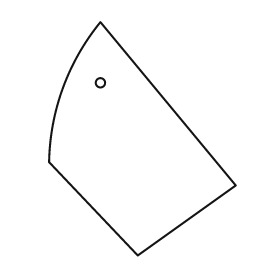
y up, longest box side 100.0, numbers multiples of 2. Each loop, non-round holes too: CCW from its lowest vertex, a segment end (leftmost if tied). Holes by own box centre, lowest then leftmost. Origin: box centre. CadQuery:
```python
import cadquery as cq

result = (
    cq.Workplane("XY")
    .moveTo(-2.0, -50.0)
    .lineTo(40.0, -20.0)
    .lineTo(-18.0, 50.0)
    .threePointArc((-34.0, 22.0), (-40.0, -10.0))
    .close()
    .moveTo(-18.0, 24.0)
    .circle(2.0)
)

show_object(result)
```